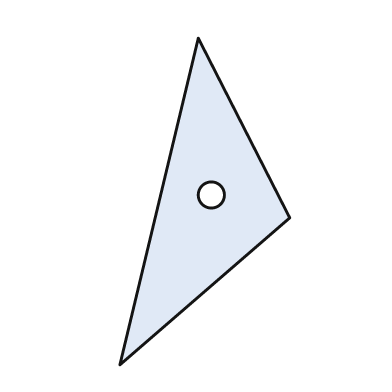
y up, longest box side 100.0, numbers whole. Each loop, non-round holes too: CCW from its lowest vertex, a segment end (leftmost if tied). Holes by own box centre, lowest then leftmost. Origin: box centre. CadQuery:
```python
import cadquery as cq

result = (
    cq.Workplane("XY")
    .moveTo(-26.0, -50.0)
    .lineTo(26.0, -5.0)
    .lineTo(-2.0, 50.0)
    .close()
    .moveTo(2.0, 2.0)
    .circle(4.0)
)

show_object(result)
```